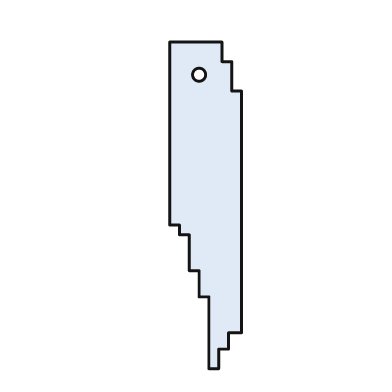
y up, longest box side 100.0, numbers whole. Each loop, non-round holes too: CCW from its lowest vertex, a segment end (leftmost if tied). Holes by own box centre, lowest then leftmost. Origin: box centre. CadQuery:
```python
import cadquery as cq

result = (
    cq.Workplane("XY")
    .moveTo(1.0, -50.0)
    .lineTo(4.0, -50.0)
    .lineTo(4.0, -44.0)
    .lineTo(7.0, -44.0)
    .lineTo(7.0, -39.0)
    .lineTo(11.0, -39.0)
    .lineTo(11.0, 35.0)
    .lineTo(8.0, 35.0)
    .lineTo(8.0, 44.0)
    .lineTo(5.0, 44.0)
    .lineTo(5.0, 50.0)
    .lineTo(-11.0, 50.0)
    .lineTo(-11.0, -6.0)
    .lineTo(-8.0, -6.0)
    .lineTo(-8.0, -9.0)
    .lineTo(-5.0, -9.0)
    .lineTo(-5.0, -20.0)
    .lineTo(-2.0, -20.0)
    .lineTo(-2.0, -28.0)
    .lineTo(1.0, -28.0)
    .close()
    .moveTo(-2.0, 40.0)
    .circle(2.0)
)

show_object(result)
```